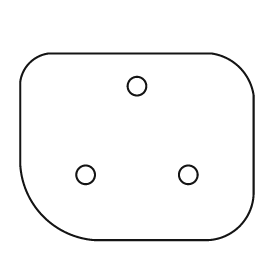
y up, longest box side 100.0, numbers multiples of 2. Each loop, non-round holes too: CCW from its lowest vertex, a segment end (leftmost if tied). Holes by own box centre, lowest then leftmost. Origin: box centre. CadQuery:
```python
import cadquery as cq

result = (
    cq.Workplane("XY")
    .moveTo(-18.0, -40.0)
    .lineTo(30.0, -40.0)
    .threePointArc((44.0, -34.0), (50.0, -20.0))
    .lineTo(50.0, 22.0)
    .threePointArc((44.0, 34.0), (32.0, 40.0))
    .lineTo(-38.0, 40.0)
    .threePointArc((-46.0, 36.0), (-50.0, 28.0))
    .lineTo(-50.0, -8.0)
    .threePointArc((-40.0, -30.0), (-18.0, -40.0))
    .close()
    .moveTo(-22.0, -12.0)
    .circle(4.0)
    .moveTo(22.0, -12.0)
    .circle(4.0)
    .moveTo(0.0, 26.0)
    .circle(4.0)
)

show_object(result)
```